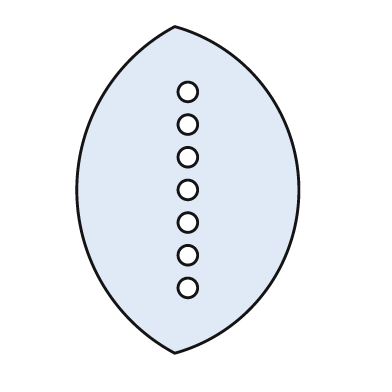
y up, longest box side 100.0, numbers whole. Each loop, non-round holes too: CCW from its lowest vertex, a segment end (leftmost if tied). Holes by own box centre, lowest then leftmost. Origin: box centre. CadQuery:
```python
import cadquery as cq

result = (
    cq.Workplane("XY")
    .moveTo(-4.0, -50.0)
    .threePointArc((34.0, 0.0), (-4.0, 50.0))
    .threePointArc((-34.0, 0.0), (-4.0, -50.0))
    .close()
    .moveTo(0.0, -30.0)
    .circle(3.0)
    .moveTo(0.0, -20.0)
    .circle(3.0)
    .moveTo(0.0, -10.0)
    .circle(3.0)
    .moveTo(0.0, 0.0)
    .circle(3.0)
    .moveTo(0.0, 10.0)
    .circle(3.0)
    .moveTo(0.0, 20.0)
    .circle(3.0)
    .moveTo(0.0, 30.0)
    .circle(3.0)
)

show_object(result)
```